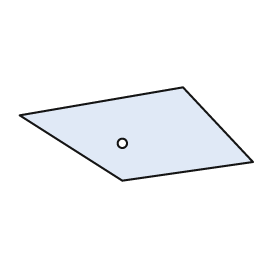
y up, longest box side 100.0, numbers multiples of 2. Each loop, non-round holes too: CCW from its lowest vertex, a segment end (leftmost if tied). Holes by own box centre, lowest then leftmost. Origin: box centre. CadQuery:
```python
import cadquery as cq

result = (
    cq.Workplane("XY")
    .moveTo(-6.0, -20.0)
    .lineTo(50.0, -12.0)
    .lineTo(20.0, 20.0)
    .lineTo(-50.0, 8.0)
    .close()
    .moveTo(-6.0, -4.0)
    .circle(2.0)
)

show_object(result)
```